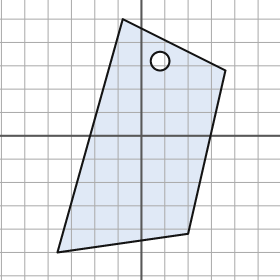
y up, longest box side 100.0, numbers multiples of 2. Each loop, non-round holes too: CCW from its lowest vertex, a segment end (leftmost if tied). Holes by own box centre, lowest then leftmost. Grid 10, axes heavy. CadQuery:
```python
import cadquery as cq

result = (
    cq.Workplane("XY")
    .moveTo(-36.0, -50.0)
    .lineTo(20.0, -42.0)
    .lineTo(36.0, 28.0)
    .lineTo(-8.0, 50.0)
    .close()
    .moveTo(8.0, 32.0)
    .circle(4.0)
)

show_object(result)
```